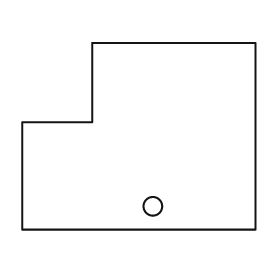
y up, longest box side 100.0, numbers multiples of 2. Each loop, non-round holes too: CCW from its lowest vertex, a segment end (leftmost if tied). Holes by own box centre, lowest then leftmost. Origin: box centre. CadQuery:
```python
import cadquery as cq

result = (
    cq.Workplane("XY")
    .moveTo(-50.0, -40.0)
    .lineTo(50.0, -40.0)
    .lineTo(50.0, 40.0)
    .lineTo(-20.0, 40.0)
    .lineTo(-20.0, 6.0)
    .lineTo(-50.0, 6.0)
    .close()
    .moveTo(6.0, -30.0)
    .circle(4.0)
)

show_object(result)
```